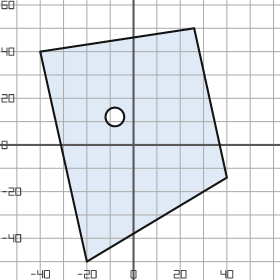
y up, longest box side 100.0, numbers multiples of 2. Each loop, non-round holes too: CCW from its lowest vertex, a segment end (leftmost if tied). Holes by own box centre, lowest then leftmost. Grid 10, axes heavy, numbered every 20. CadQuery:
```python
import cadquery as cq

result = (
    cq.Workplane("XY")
    .moveTo(-20.0, -50.0)
    .lineTo(40.0, -14.0)
    .lineTo(26.0, 50.0)
    .lineTo(-40.0, 40.0)
    .close()
    .moveTo(-8.0, 12.0)
    .circle(4.0)
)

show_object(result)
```